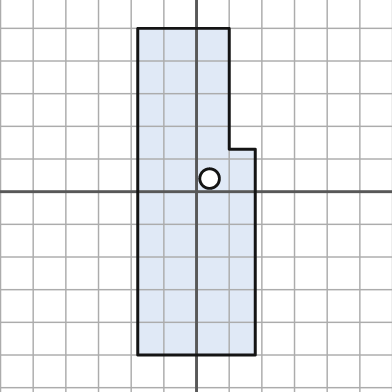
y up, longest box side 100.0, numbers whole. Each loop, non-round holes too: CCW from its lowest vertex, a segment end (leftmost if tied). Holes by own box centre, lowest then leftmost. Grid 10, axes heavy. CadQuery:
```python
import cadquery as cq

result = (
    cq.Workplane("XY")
    .moveTo(-18.0, -50.0)
    .lineTo(18.0, -50.0)
    .lineTo(18.0, 13.0)
    .lineTo(10.0, 13.0)
    .lineTo(10.0, 50.0)
    .lineTo(-18.0, 50.0)
    .close()
    .moveTo(4.0, 4.0)
    .circle(3.0)
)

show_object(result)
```